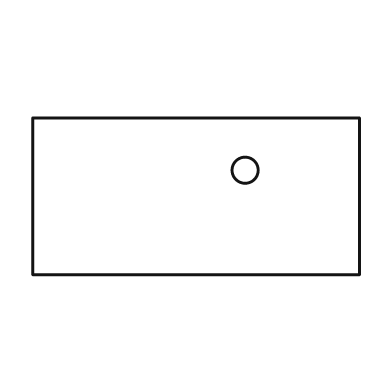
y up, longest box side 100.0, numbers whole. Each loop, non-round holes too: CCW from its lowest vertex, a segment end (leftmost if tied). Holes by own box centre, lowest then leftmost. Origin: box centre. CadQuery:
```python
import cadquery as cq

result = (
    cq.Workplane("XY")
    .moveTo(-50.0, -24.0)
    .lineTo(50.0, -24.0)
    .lineTo(50.0, 24.0)
    .lineTo(-50.0, 24.0)
    .close()
    .moveTo(15.0, 8.0)
    .circle(4.0)
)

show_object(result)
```